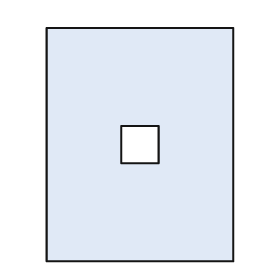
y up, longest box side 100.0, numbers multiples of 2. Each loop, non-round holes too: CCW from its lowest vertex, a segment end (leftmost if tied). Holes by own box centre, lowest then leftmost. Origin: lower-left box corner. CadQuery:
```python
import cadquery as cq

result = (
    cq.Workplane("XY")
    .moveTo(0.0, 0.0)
    .lineTo(80.0, 0.0)
    .lineTo(80.0, 100.0)
    .lineTo(0.0, 100.0)
    .close()
    .moveTo(32.0, 42.0)
    .lineTo(48.0, 42.0)
    .lineTo(48.0, 58.0)
    .lineTo(32.0, 58.0)
    .close()
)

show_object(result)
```